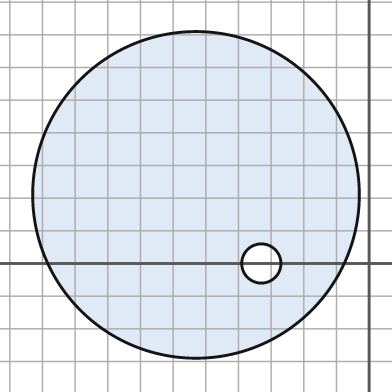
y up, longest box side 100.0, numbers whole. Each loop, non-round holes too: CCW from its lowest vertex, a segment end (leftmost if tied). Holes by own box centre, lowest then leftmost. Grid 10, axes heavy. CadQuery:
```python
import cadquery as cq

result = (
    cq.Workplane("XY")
    .moveTo(-53.0, 21.0)
    .circle(50.0)
    .moveTo(-33.0, 0.0)
    .circle(6.0)
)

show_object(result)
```